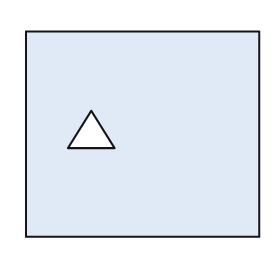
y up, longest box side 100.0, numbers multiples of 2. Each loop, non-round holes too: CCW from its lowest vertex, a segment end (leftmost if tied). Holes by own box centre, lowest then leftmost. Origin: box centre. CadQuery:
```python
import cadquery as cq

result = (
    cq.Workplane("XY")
    .moveTo(-50.0, -44.0)
    .lineTo(50.0, -44.0)
    .lineTo(50.0, 44.0)
    .lineTo(-50.0, 44.0)
    .close()
    .moveTo(-32.0, -6.0)
    .lineTo(-12.0, -6.0)
    .lineTo(-22.0, 10.0)
    .close()
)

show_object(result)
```